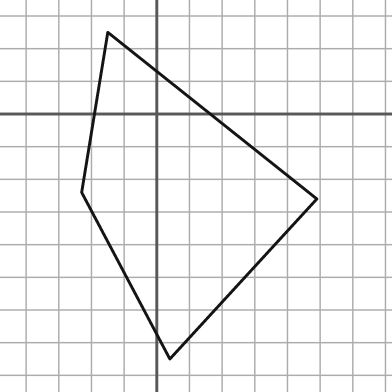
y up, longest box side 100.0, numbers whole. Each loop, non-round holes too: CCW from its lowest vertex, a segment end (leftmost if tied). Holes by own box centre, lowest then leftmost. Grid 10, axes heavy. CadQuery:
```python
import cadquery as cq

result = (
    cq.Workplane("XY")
    .moveTo(4.0, -75.0)
    .lineTo(49.0, -26.0)
    .lineTo(-15.0, 25.0)
    .lineTo(-23.0, -24.0)
    .close()
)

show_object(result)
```